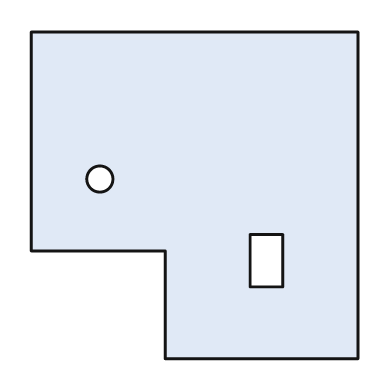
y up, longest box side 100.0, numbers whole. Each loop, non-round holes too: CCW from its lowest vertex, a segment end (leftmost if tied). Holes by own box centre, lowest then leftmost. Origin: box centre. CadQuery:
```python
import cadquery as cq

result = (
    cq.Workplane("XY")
    .moveTo(-9.0, -50.0)
    .lineTo(50.0, -50.0)
    .lineTo(50.0, 50.0)
    .lineTo(-50.0, 50.0)
    .lineTo(-50.0, -17.0)
    .lineTo(-9.0, -17.0)
    .close()
    .moveTo(17.0, -28.0)
    .lineTo(27.0, -28.0)
    .lineTo(27.0, -12.0)
    .lineTo(17.0, -12.0)
    .close()
    .moveTo(-29.0, 5.0)
    .circle(4.0)
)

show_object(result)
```